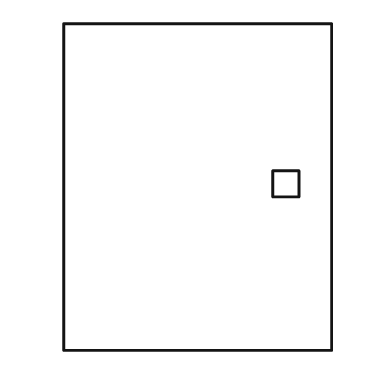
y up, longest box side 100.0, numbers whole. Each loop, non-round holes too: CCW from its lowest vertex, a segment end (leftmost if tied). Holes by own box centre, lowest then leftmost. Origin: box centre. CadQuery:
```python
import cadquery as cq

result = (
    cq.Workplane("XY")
    .moveTo(-41.0, -50.0)
    .lineTo(41.0, -50.0)
    .lineTo(41.0, 50.0)
    .lineTo(-41.0, 50.0)
    .close()
    .moveTo(23.0, -3.0)
    .lineTo(31.0, -3.0)
    .lineTo(31.0, 5.0)
    .lineTo(23.0, 5.0)
    .close()
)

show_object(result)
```